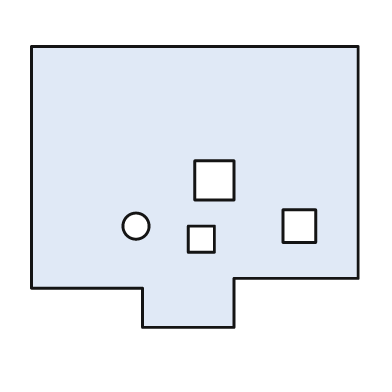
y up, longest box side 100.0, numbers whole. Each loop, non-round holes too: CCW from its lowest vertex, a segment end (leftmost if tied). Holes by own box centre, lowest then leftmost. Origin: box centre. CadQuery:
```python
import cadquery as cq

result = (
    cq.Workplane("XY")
    .moveTo(-16.0, -43.0)
    .lineTo(12.0, -43.0)
    .lineTo(12.0, -28.0)
    .lineTo(50.0, -28.0)
    .lineTo(50.0, 43.0)
    .lineTo(-50.0, 43.0)
    .lineTo(-50.0, -31.0)
    .lineTo(-16.0, -31.0)
    .close()
    .moveTo(-2.0, -20.0)
    .lineTo(6.0, -20.0)
    .lineTo(6.0, -12.0)
    .lineTo(-2.0, -12.0)
    .close()
    .moveTo(-18.0, -12.0)
    .circle(4.0)
    .moveTo(27.0, -17.0)
    .lineTo(37.0, -17.0)
    .lineTo(37.0, -7.0)
    .lineTo(27.0, -7.0)
    .close()
    .moveTo(0.0, -4.0)
    .lineTo(12.0, -4.0)
    .lineTo(12.0, 8.0)
    .lineTo(0.0, 8.0)
    .close()
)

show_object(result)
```